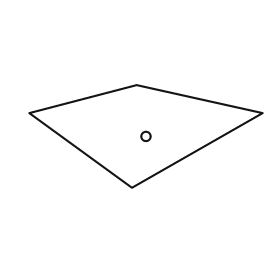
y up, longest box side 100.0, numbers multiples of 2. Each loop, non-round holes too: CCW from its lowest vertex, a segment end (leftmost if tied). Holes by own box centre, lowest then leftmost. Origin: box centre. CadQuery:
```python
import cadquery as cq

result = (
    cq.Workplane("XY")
    .moveTo(-6.0, -22.0)
    .lineTo(50.0, 10.0)
    .lineTo(-4.0, 22.0)
    .lineTo(-50.0, 10.0)
    .close()
    .moveTo(0.0, 0.0)
    .circle(2.0)
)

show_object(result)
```